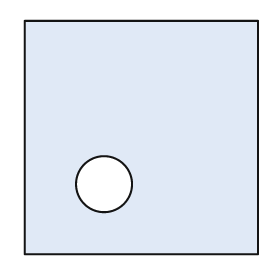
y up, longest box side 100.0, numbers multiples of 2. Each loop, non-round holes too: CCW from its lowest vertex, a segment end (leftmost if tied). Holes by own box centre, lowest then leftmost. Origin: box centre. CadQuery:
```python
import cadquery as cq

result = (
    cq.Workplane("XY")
    .moveTo(-50.0, -50.0)
    .lineTo(50.0, -50.0)
    .lineTo(50.0, 50.0)
    .lineTo(-50.0, 50.0)
    .close()
    .moveTo(-16.0, -20.0)
    .circle(12.0)
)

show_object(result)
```